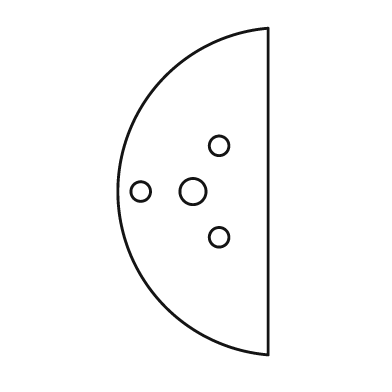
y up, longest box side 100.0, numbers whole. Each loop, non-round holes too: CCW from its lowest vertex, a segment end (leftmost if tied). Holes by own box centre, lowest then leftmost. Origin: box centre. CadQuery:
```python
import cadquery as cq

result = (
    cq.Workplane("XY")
    .moveTo(23.0, -50.0)
    .lineTo(23.0, 50.0)
    .threePointArc((-23.0, 0.0), (23.0, -50.0))
    .close()
    .moveTo(8.0, -14.0)
    .circle(3.0)
    .moveTo(-16.0, 0.0)
    .circle(3.0)
    .moveTo(0.0, 0.0)
    .circle(4.0)
    .moveTo(8.0, 14.0)
    .circle(3.0)
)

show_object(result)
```